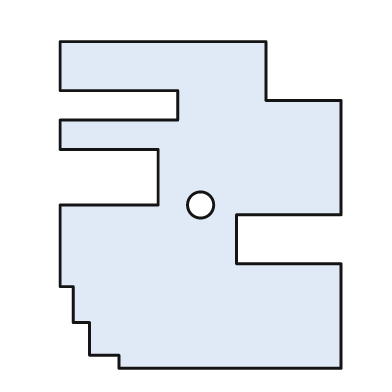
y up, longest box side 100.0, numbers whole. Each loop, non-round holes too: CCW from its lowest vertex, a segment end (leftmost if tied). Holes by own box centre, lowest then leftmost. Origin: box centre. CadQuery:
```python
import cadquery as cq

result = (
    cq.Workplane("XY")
    .moveTo(-25.0, -50.0)
    .lineTo(43.0, -50.0)
    .lineTo(43.0, -18.0)
    .lineTo(11.0, -18.0)
    .lineTo(11.0, -3.0)
    .lineTo(43.0, -3.0)
    .lineTo(43.0, 32.0)
    .lineTo(20.0, 32.0)
    .lineTo(20.0, 50.0)
    .lineTo(-43.0, 50.0)
    .lineTo(-43.0, 35.0)
    .lineTo(-7.0, 35.0)
    .lineTo(-7.0, 26.0)
    .lineTo(-43.0, 26.0)
    .lineTo(-43.0, 17.0)
    .lineTo(-13.0, 17.0)
    .lineTo(-13.0, 0.0)
    .lineTo(-43.0, 0.0)
    .lineTo(-43.0, -25.0)
    .lineTo(-39.0, -25.0)
    .lineTo(-39.0, -36.0)
    .lineTo(-34.0, -36.0)
    .lineTo(-34.0, -46.0)
    .lineTo(-25.0, -46.0)
    .close()
    .moveTo(0.0, 0.0)
    .circle(4.0)
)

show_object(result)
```